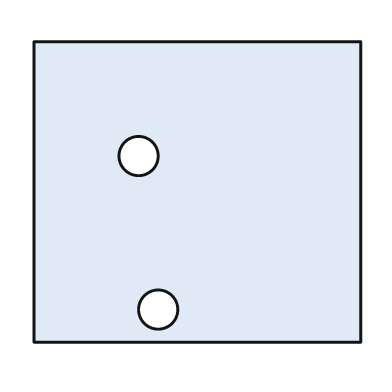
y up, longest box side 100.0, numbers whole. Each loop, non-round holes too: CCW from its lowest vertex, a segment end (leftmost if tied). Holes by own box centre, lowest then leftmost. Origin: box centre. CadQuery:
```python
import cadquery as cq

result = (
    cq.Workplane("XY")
    .moveTo(-50.0, -46.0)
    .lineTo(50.0, -46.0)
    .lineTo(50.0, 46.0)
    .lineTo(-50.0, 46.0)
    .close()
    .moveTo(-12.0, -36.0)
    .circle(6.0)
    .moveTo(-18.0, 11.0)
    .circle(6.0)
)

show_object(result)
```